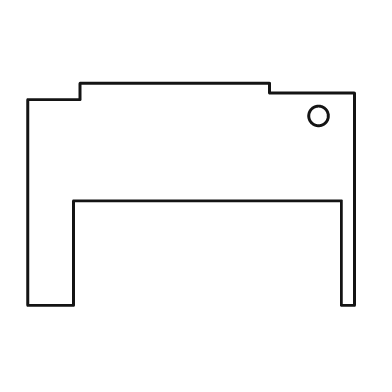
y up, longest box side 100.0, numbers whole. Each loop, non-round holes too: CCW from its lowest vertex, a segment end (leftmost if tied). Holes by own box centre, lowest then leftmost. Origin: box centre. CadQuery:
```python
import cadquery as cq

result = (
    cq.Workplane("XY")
    .moveTo(-50.0, -34.0)
    .lineTo(-36.0, -34.0)
    .lineTo(-36.0, -2.0)
    .lineTo(46.0, -2.0)
    .lineTo(46.0, -34.0)
    .lineTo(50.0, -34.0)
    .lineTo(50.0, 31.0)
    .lineTo(24.0, 31.0)
    .lineTo(24.0, 34.0)
    .lineTo(-34.0, 34.0)
    .lineTo(-34.0, 29.0)
    .lineTo(-50.0, 29.0)
    .close()
    .moveTo(39.0, 24.0)
    .circle(3.0)
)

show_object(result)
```